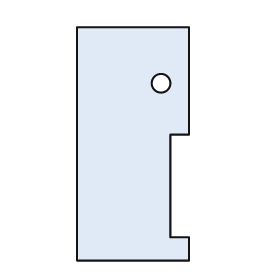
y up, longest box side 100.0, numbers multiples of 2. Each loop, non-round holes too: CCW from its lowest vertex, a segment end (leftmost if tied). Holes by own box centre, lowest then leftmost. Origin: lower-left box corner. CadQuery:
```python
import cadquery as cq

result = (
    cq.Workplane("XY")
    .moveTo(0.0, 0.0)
    .lineTo(48.0, 0.0)
    .lineTo(48.0, 10.0)
    .lineTo(40.0, 10.0)
    .lineTo(40.0, 54.0)
    .lineTo(48.0, 54.0)
    .lineTo(48.0, 100.0)
    .lineTo(0.0, 100.0)
    .close()
    .moveTo(36.0, 76.0)
    .circle(4.0)
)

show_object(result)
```